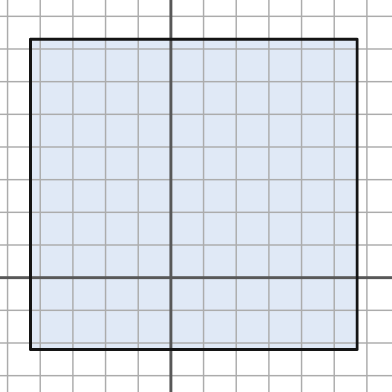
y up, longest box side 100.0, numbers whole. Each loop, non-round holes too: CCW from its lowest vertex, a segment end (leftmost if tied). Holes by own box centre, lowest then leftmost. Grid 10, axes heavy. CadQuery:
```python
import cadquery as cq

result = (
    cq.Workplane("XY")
    .moveTo(-43.0, -22.0)
    .lineTo(57.0, -22.0)
    .lineTo(57.0, 73.0)
    .lineTo(-43.0, 73.0)
    .close()
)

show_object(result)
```